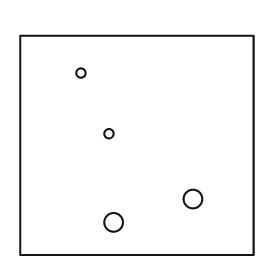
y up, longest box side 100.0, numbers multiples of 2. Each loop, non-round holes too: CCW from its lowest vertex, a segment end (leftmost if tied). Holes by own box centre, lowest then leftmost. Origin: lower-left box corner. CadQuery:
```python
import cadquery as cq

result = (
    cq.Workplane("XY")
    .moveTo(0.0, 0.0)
    .lineTo(100.0, 0.0)
    .lineTo(100.0, 94.0)
    .lineTo(0.0, 94.0)
    .close()
    .moveTo(40.0, 14.0)
    .circle(4.0)
    .moveTo(74.0, 24.0)
    .circle(4.0)
    .moveTo(38.0, 52.0)
    .circle(2.0)
    .moveTo(26.0, 78.0)
    .circle(2.0)
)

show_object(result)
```